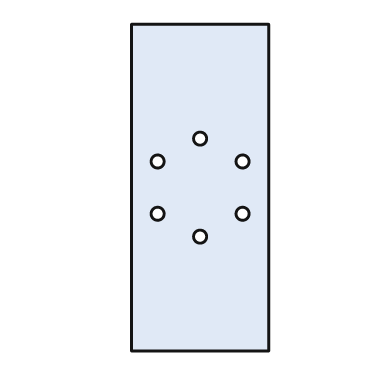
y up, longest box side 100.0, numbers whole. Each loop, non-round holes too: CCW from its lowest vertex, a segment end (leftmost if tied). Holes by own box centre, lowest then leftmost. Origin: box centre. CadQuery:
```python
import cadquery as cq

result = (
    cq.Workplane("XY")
    .moveTo(-21.0, -50.0)
    .lineTo(21.0, -50.0)
    .lineTo(21.0, 50.0)
    .lineTo(-21.0, 50.0)
    .close()
    .moveTo(0.0, -15.0)
    .circle(2.0)
    .moveTo(-13.0, -8.0)
    .circle(2.0)
    .moveTo(13.0, -8.0)
    .circle(2.0)
    .moveTo(-13.0, 8.0)
    .circle(2.0)
    .moveTo(13.0, 8.0)
    .circle(2.0)
    .moveTo(0.0, 15.0)
    .circle(2.0)
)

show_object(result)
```